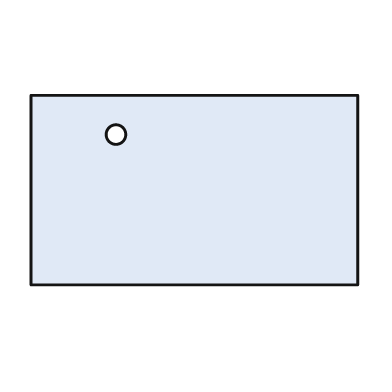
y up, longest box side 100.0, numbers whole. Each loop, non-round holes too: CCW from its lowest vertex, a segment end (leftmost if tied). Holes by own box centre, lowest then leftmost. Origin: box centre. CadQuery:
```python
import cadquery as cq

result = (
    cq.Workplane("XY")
    .moveTo(-50.0, -29.0)
    .lineTo(50.0, -29.0)
    .lineTo(50.0, 29.0)
    .lineTo(-50.0, 29.0)
    .close()
    .moveTo(-24.0, 17.0)
    .circle(3.0)
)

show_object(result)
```